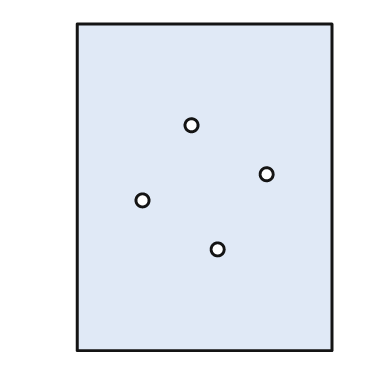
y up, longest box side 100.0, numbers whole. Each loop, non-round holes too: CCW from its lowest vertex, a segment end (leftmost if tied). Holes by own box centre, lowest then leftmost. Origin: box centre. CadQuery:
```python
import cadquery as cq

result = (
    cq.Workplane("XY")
    .moveTo(-39.0, -50.0)
    .lineTo(39.0, -50.0)
    .lineTo(39.0, 50.0)
    .lineTo(-39.0, 50.0)
    .close()
    .moveTo(4.0, -19.0)
    .circle(2.0)
    .moveTo(-19.0, -4.0)
    .circle(2.0)
    .moveTo(19.0, 4.0)
    .circle(2.0)
    .moveTo(-4.0, 19.0)
    .circle(2.0)
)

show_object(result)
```